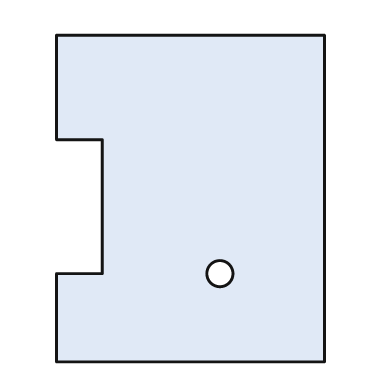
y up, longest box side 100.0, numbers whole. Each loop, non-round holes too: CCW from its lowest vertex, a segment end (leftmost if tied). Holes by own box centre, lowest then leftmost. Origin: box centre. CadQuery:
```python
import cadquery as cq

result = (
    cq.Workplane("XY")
    .moveTo(-41.0, -50.0)
    .lineTo(41.0, -50.0)
    .lineTo(41.0, 50.0)
    .lineTo(-41.0, 50.0)
    .lineTo(-41.0, 18.0)
    .lineTo(-27.0, 18.0)
    .lineTo(-27.0, -23.0)
    .lineTo(-41.0, -23.0)
    .close()
    .moveTo(9.0, -23.0)
    .circle(4.0)
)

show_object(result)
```